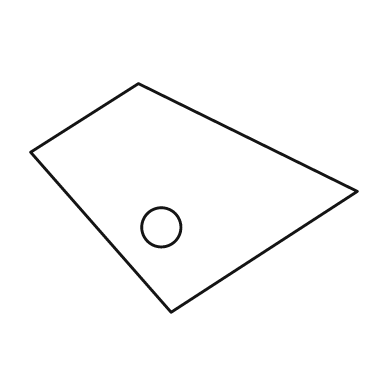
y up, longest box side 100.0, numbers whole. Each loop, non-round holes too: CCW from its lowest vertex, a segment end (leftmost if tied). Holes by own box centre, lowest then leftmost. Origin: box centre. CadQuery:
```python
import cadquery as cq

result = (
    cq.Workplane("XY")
    .moveTo(-7.0, -35.0)
    .lineTo(50.0, 2.0)
    .lineTo(-17.0, 35.0)
    .lineTo(-50.0, 14.0)
    .close()
    .moveTo(-10.0, -9.0)
    .circle(6.0)
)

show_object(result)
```